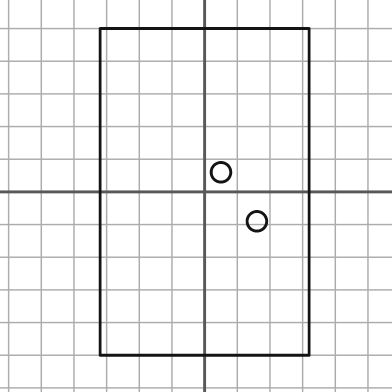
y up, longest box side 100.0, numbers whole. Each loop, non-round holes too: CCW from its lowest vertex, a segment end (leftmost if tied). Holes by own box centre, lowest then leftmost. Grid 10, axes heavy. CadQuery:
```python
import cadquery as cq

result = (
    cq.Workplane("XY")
    .moveTo(-32.0, -50.0)
    .lineTo(32.0, -50.0)
    .lineTo(32.0, 50.0)
    .lineTo(-32.0, 50.0)
    .close()
    .moveTo(16.0, -9.0)
    .circle(3.0)
    .moveTo(5.0, 6.0)
    .circle(3.0)
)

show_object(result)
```